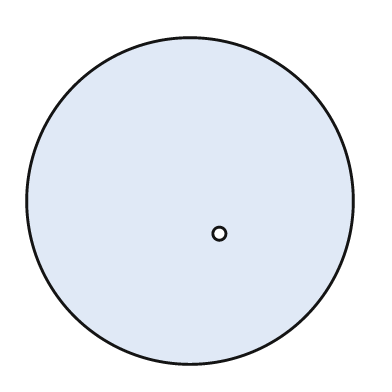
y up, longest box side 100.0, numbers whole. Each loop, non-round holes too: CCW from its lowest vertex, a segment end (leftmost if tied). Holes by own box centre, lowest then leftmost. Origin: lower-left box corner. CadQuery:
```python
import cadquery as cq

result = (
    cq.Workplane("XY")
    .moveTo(50.0, 50.0)
    .circle(50.0)
    .moveTo(59.0, 40.0)
    .circle(2.0)
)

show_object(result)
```